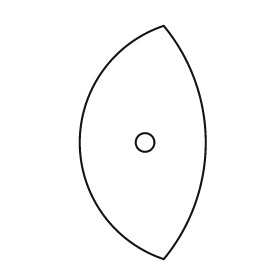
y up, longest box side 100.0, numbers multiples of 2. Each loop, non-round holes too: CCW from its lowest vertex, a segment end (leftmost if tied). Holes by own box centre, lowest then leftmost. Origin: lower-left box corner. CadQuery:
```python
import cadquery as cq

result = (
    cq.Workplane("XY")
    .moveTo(36.0, 0.0)
    .threePointArc((54.0, 50.0), (36.0, 100.0))
    .threePointArc((0.0, 50.0), (36.0, 0.0))
    .close()
    .moveTo(28.0, 50.0)
    .circle(4.0)
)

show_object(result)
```